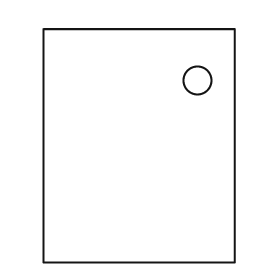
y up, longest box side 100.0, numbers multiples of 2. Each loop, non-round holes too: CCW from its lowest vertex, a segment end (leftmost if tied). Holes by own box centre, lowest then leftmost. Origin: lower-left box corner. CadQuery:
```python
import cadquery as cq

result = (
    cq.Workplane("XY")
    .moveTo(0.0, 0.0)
    .lineTo(82.0, 0.0)
    .lineTo(82.0, 100.0)
    .lineTo(0.0, 100.0)
    .close()
    .moveTo(66.0, 78.0)
    .circle(6.0)
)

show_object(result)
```